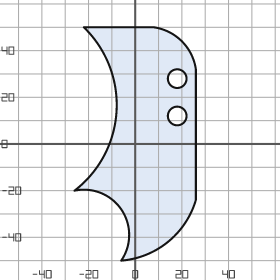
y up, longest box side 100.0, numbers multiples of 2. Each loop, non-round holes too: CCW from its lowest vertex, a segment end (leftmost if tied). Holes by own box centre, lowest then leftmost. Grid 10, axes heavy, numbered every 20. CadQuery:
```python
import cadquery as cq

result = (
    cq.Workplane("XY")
    .moveTo(-6.0, -50.0)
    .threePointArc((14.0, -42.0), (26.0, -24.0))
    .lineTo(26.0, 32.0)
    .threePointArc((20.0, 44.0), (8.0, 50.0))
    .lineTo(-22.0, 50.0)
    .threePointArc((-8.0, 14.0), (-26.0, -20.0))
    .threePointArc((-6.0, -28.0), (-6.0, -50.0))
    .close()
    .moveTo(18.0, 12.0)
    .circle(4.0)
    .moveTo(18.0, 28.0)
    .circle(4.0)
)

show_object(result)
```